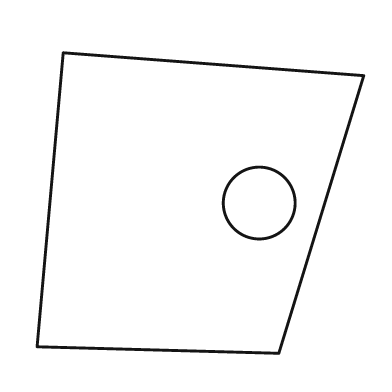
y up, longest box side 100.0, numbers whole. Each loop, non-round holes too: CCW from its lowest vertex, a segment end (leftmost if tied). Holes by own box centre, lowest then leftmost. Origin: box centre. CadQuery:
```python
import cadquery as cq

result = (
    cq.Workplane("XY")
    .moveTo(24.0, -46.0)
    .lineTo(50.0, 39.0)
    .lineTo(-42.0, 46.0)
    .lineTo(-50.0, -44.0)
    .close()
    .moveTo(18.0, 0.0)
    .circle(11.0)
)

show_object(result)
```